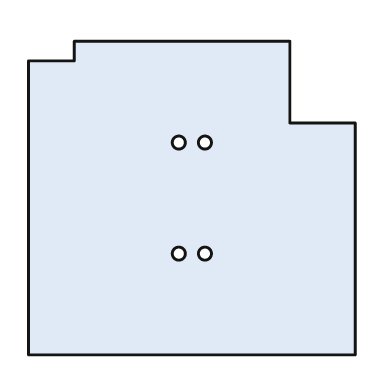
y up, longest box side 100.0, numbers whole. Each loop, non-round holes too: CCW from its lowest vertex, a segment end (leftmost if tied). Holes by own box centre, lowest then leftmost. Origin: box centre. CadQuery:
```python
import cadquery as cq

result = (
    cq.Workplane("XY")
    .moveTo(-50.0, -48.0)
    .lineTo(50.0, -48.0)
    .lineTo(50.0, 23.0)
    .lineTo(30.0, 23.0)
    .lineTo(30.0, 48.0)
    .lineTo(-36.0, 48.0)
    .lineTo(-36.0, 42.0)
    .lineTo(-50.0, 42.0)
    .close()
    .moveTo(-4.0, -17.0)
    .circle(2.0)
    .moveTo(4.0, -17.0)
    .circle(2.0)
    .moveTo(-4.0, 17.0)
    .circle(2.0)
    .moveTo(4.0, 17.0)
    .circle(2.0)
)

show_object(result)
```